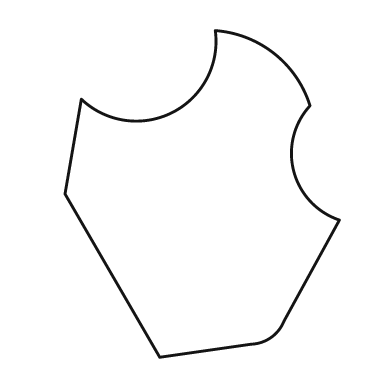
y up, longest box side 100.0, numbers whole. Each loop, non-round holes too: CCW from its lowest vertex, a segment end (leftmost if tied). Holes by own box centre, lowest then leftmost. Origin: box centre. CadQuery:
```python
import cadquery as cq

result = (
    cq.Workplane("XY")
    .moveTo(-13.0, -50.0)
    .lineTo(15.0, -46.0)
    .threePointArc((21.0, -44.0), (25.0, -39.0))
    .lineTo(42.0, -8.0)
    .threePointArc((28.0, 7.0), (33.0, 27.0))
    .threePointArc((22.0, 43.0), (4.0, 50.0))
    .threePointArc((-9.0, 25.0), (-37.0, 29.0))
    .lineTo(-42.0, 0.0)
    .close()
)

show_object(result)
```